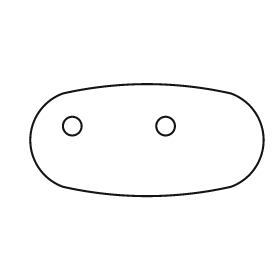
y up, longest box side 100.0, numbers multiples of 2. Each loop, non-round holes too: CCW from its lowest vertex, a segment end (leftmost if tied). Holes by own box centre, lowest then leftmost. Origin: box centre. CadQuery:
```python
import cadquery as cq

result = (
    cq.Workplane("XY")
    .moveTo(-36.0, -20.0)
    .threePointArc((0.0, -24.0), (36.0, -20.0))
    .threePointArc((50.0, 0.0), (36.0, 20.0))
    .threePointArc((0.0, 24.0), (-36.0, 20.0))
    .threePointArc((-50.0, 0.0), (-36.0, -20.0))
    .close()
    .moveTo(-32.0, 6.0)
    .circle(4.0)
    .moveTo(8.0, 6.0)
    .circle(4.0)
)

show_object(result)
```